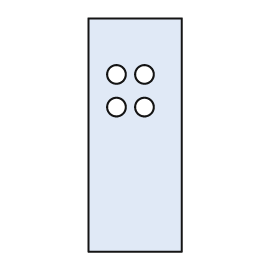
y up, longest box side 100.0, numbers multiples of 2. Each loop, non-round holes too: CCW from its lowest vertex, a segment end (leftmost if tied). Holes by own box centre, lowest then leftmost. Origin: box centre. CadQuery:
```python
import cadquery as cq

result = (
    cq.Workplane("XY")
    .moveTo(-20.0, -50.0)
    .lineTo(20.0, -50.0)
    .lineTo(20.0, 50.0)
    .lineTo(-20.0, 50.0)
    .close()
    .moveTo(-8.0, 12.0)
    .circle(4.0)
    .moveTo(4.0, 12.0)
    .circle(4.0)
    .moveTo(-8.0, 26.0)
    .circle(4.0)
    .moveTo(4.0, 26.0)
    .circle(4.0)
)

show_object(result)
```